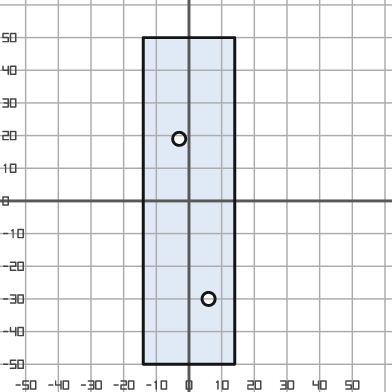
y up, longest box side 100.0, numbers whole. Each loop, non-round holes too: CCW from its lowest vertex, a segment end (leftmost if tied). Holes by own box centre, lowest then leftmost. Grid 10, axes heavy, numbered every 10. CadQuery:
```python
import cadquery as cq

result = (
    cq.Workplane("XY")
    .moveTo(-14.0, -50.0)
    .lineTo(14.0, -50.0)
    .lineTo(14.0, 50.0)
    .lineTo(-14.0, 50.0)
    .close()
    .moveTo(6.0, -30.0)
    .circle(2.0)
    .moveTo(-3.0, 19.0)
    .circle(2.0)
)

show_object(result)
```